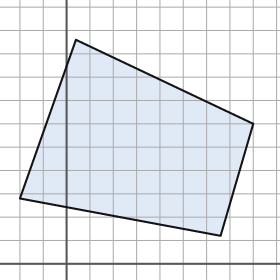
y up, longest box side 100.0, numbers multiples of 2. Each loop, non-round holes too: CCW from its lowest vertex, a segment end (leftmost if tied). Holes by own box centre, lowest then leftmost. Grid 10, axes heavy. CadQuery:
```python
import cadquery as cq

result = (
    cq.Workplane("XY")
    .moveTo(66.0, 12.0)
    .lineTo(80.0, 60.0)
    .lineTo(4.0, 96.0)
    .lineTo(-20.0, 28.0)
    .close()
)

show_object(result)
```